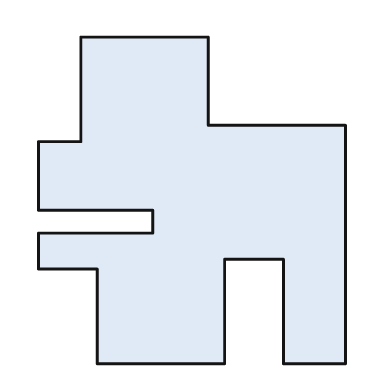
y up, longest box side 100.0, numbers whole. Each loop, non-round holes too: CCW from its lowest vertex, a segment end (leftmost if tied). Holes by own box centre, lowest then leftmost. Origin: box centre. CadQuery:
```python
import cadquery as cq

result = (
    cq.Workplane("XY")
    .moveTo(-29.0, -50.0)
    .lineTo(10.0, -50.0)
    .lineTo(10.0, -18.0)
    .lineTo(28.0, -18.0)
    .lineTo(28.0, -50.0)
    .lineTo(47.0, -50.0)
    .lineTo(47.0, 23.0)
    .lineTo(5.0, 23.0)
    .lineTo(5.0, 50.0)
    .lineTo(-34.0, 50.0)
    .lineTo(-34.0, 18.0)
    .lineTo(-47.0, 18.0)
    .lineTo(-47.0, -3.0)
    .lineTo(-12.0, -3.0)
    .lineTo(-12.0, -10.0)
    .lineTo(-47.0, -10.0)
    .lineTo(-47.0, -21.0)
    .lineTo(-29.0, -21.0)
    .close()
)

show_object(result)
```